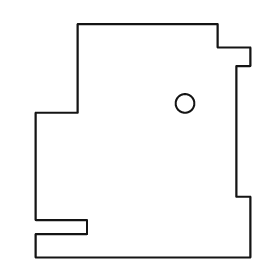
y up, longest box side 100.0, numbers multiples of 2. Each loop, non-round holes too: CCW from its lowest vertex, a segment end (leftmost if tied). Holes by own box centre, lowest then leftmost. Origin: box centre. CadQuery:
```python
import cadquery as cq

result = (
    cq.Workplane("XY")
    .moveTo(-46.0, -50.0)
    .lineTo(46.0, -50.0)
    .lineTo(46.0, -24.0)
    .lineTo(40.0, -24.0)
    .lineTo(40.0, 32.0)
    .lineTo(46.0, 32.0)
    .lineTo(46.0, 40.0)
    .lineTo(32.0, 40.0)
    .lineTo(32.0, 50.0)
    .lineTo(-28.0, 50.0)
    .lineTo(-28.0, 12.0)
    .lineTo(-46.0, 12.0)
    .lineTo(-46.0, -34.0)
    .lineTo(-24.0, -34.0)
    .lineTo(-24.0, -40.0)
    .lineTo(-46.0, -40.0)
    .close()
    .moveTo(18.0, 16.0)
    .circle(4.0)
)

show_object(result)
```